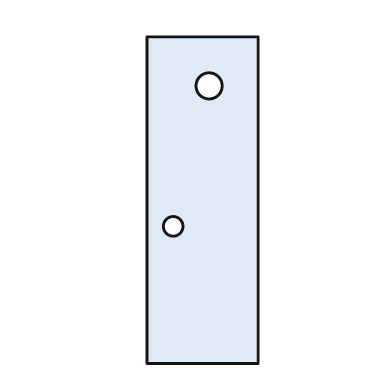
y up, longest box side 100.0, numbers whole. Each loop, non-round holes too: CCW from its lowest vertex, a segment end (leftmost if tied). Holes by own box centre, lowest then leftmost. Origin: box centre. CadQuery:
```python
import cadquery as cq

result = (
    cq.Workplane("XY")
    .moveTo(-17.0, -50.0)
    .lineTo(17.0, -50.0)
    .lineTo(17.0, 50.0)
    .lineTo(-17.0, 50.0)
    .close()
    .moveTo(-9.0, -8.0)
    .circle(3.0)
    .moveTo(2.0, 35.0)
    .circle(4.0)
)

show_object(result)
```